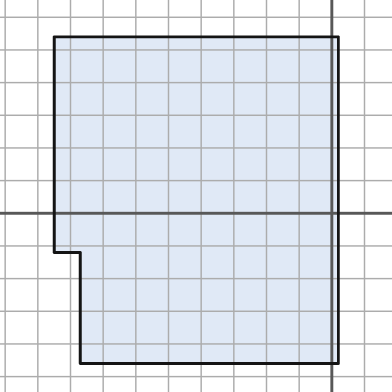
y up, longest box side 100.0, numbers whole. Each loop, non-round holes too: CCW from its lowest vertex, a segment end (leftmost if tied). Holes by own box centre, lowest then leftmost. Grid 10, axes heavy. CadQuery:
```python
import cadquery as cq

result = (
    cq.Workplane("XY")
    .moveTo(-77.0, -46.0)
    .lineTo(2.0, -46.0)
    .lineTo(2.0, 54.0)
    .lineTo(-85.0, 54.0)
    .lineTo(-85.0, -12.0)
    .lineTo(-77.0, -12.0)
    .close()
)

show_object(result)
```